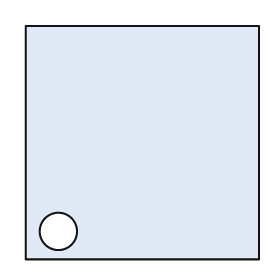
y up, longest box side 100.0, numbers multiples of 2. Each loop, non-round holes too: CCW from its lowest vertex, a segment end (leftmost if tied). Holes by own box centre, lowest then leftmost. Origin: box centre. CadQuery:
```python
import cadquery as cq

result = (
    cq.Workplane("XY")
    .moveTo(-50.0, -50.0)
    .lineTo(50.0, -50.0)
    .lineTo(50.0, 50.0)
    .lineTo(-50.0, 50.0)
    .close()
    .moveTo(-36.0, -38.0)
    .circle(8.0)
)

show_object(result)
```